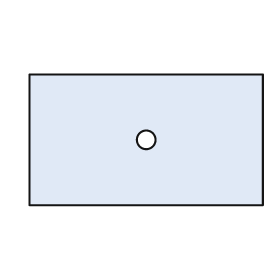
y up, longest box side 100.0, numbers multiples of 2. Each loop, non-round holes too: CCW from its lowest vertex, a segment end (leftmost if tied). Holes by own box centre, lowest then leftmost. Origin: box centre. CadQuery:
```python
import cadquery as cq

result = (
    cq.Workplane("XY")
    .moveTo(-50.0, -28.0)
    .lineTo(50.0, -28.0)
    .lineTo(50.0, 28.0)
    .lineTo(-50.0, 28.0)
    .close()
    .moveTo(0.0, 0.0)
    .circle(4.0)
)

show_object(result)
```